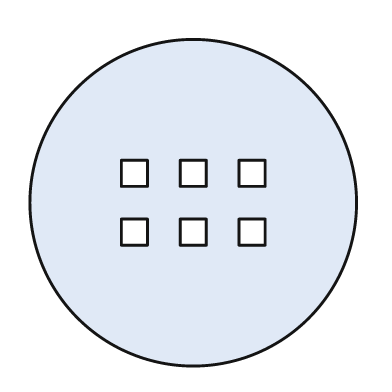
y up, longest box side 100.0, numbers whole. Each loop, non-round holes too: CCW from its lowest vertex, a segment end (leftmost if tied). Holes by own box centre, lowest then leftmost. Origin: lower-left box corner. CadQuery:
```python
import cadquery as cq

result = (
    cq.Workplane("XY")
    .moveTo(50.0, 50.0)
    .circle(50.0)
    .moveTo(28.0, 37.0)
    .lineTo(36.0, 37.0)
    .lineTo(36.0, 45.0)
    .lineTo(28.0, 45.0)
    .close()
    .moveTo(46.0, 37.0)
    .lineTo(54.0, 37.0)
    .lineTo(54.0, 45.0)
    .lineTo(46.0, 45.0)
    .close()
    .moveTo(64.0, 37.0)
    .lineTo(72.0, 37.0)
    .lineTo(72.0, 45.0)
    .lineTo(64.0, 45.0)
    .close()
    .moveTo(28.0, 55.0)
    .lineTo(36.0, 55.0)
    .lineTo(36.0, 63.0)
    .lineTo(28.0, 63.0)
    .close()
    .moveTo(46.0, 55.0)
    .lineTo(54.0, 55.0)
    .lineTo(54.0, 63.0)
    .lineTo(46.0, 63.0)
    .close()
    .moveTo(64.0, 55.0)
    .lineTo(72.0, 55.0)
    .lineTo(72.0, 63.0)
    .lineTo(64.0, 63.0)
    .close()
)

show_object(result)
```